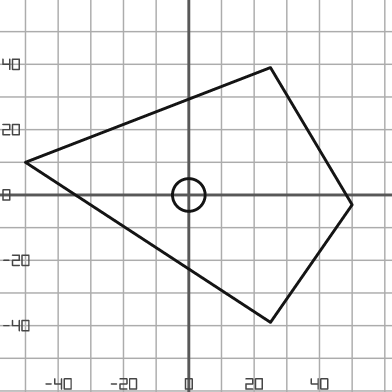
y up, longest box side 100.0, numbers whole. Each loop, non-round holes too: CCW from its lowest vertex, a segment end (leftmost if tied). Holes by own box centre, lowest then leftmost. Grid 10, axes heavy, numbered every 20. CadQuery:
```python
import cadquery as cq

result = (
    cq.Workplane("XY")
    .moveTo(25.0, -39.0)
    .lineTo(50.0, -3.0)
    .lineTo(25.0, 39.0)
    .lineTo(-50.0, 10.0)
    .close()
    .moveTo(0.0, 0.0)
    .circle(5.0)
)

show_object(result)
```